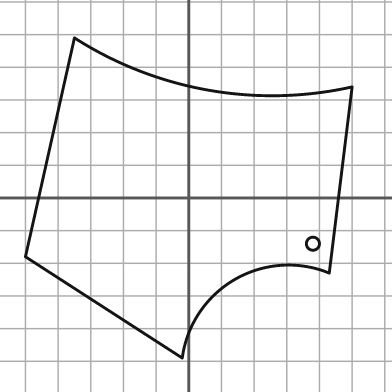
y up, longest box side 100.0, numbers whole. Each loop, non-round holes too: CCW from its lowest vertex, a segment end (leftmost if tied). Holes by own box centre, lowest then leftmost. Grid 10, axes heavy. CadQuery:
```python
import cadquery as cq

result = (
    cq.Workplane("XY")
    .moveTo(-2.0, -49.0)
    .threePointArc((14.0, -25.0), (43.0, -23.0))
    .lineTo(50.0, 34.0)
    .threePointArc((6.0, 33.0), (-35.0, 49.0))
    .lineTo(-50.0, -18.0)
    .close()
    .moveTo(38.0, -14.0)
    .circle(2.0)
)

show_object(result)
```